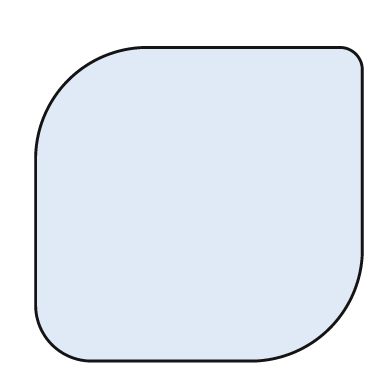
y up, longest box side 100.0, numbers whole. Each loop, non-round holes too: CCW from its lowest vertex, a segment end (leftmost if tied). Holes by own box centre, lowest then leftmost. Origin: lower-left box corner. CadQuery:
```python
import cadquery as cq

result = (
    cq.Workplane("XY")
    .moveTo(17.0, 0.0)
    .lineTo(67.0, 0.0)
    .threePointArc((90.0, 10.0), (100.0, 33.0))
    .lineTo(100.0, 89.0)
    .threePointArc((98.0, 94.0), (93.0, 96.0))
    .lineTo(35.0, 96.0)
    .threePointArc((10.0, 86.0), (0.0, 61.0))
    .lineTo(0.0, 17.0)
    .threePointArc((5.0, 5.0), (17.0, 0.0))
    .close()
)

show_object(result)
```